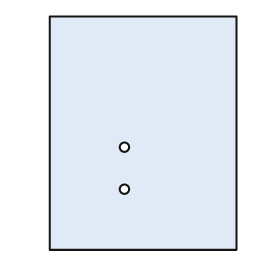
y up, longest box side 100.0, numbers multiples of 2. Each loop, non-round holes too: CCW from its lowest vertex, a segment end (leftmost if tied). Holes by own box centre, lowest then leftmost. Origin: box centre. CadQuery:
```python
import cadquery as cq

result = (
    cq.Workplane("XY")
    .moveTo(-40.0, -50.0)
    .lineTo(40.0, -50.0)
    .lineTo(40.0, 50.0)
    .lineTo(-40.0, 50.0)
    .close()
    .moveTo(-8.0, -24.0)
    .circle(2.0)
    .moveTo(-8.0, -6.0)
    .circle(2.0)
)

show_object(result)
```